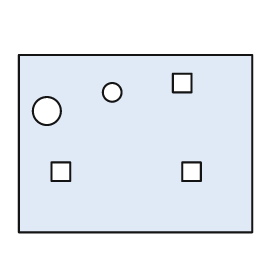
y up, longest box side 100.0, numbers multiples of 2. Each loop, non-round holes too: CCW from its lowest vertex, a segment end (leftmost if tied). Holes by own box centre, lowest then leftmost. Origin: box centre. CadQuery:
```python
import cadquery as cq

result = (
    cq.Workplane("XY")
    .moveTo(-50.0, -38.0)
    .lineTo(50.0, -38.0)
    .lineTo(50.0, 38.0)
    .lineTo(-50.0, 38.0)
    .close()
    .moveTo(-36.0, -16.0)
    .lineTo(-28.0, -16.0)
    .lineTo(-28.0, -8.0)
    .lineTo(-36.0, -8.0)
    .close()
    .moveTo(20.0, -16.0)
    .lineTo(28.0, -16.0)
    .lineTo(28.0, -8.0)
    .lineTo(20.0, -8.0)
    .close()
    .moveTo(-38.0, 14.0)
    .circle(6.0)
    .moveTo(-10.0, 22.0)
    .circle(4.0)
    .moveTo(16.0, 22.0)
    .lineTo(24.0, 22.0)
    .lineTo(24.0, 30.0)
    .lineTo(16.0, 30.0)
    .close()
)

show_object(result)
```